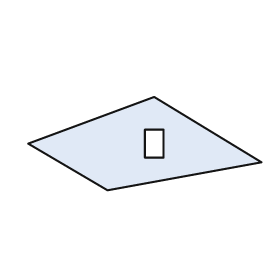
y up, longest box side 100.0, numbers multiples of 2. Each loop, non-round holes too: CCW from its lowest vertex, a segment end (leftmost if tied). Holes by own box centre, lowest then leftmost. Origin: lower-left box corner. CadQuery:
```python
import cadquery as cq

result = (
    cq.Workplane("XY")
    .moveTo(34.0, 0.0)
    .lineTo(100.0, 12.0)
    .lineTo(54.0, 40.0)
    .lineTo(0.0, 20.0)
    .close()
    .moveTo(50.0, 14.0)
    .lineTo(58.0, 14.0)
    .lineTo(58.0, 26.0)
    .lineTo(50.0, 26.0)
    .close()
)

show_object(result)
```